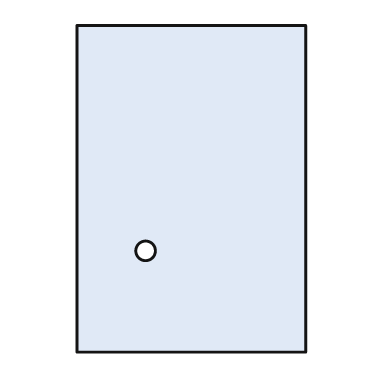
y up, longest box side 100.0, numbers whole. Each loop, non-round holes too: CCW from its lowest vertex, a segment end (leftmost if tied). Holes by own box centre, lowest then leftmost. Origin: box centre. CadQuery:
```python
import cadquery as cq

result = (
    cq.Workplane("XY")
    .moveTo(-35.0, -50.0)
    .lineTo(35.0, -50.0)
    .lineTo(35.0, 50.0)
    .lineTo(-35.0, 50.0)
    .close()
    .moveTo(-14.0, -19.0)
    .circle(3.0)
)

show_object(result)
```